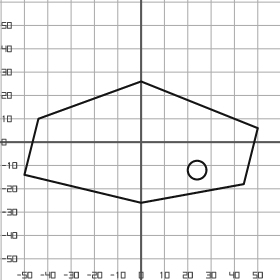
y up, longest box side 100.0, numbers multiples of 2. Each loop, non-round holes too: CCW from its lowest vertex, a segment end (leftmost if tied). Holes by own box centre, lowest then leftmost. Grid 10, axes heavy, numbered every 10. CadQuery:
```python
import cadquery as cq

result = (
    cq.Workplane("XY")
    .moveTo(0.0, -26.0)
    .lineTo(44.0, -18.0)
    .lineTo(50.0, 6.0)
    .lineTo(0.0, 26.0)
    .lineTo(-44.0, 10.0)
    .lineTo(-50.0, -14.0)
    .close()
    .moveTo(24.0, -12.0)
    .circle(4.0)
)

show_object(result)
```